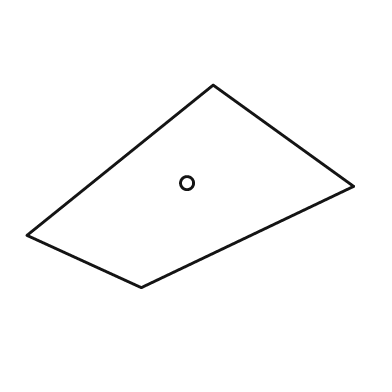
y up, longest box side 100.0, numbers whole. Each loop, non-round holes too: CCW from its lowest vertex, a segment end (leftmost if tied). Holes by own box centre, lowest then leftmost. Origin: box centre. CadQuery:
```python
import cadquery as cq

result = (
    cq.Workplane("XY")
    .moveTo(-15.0, -31.0)
    .lineTo(50.0, 0.0)
    .lineTo(7.0, 31.0)
    .lineTo(-50.0, -15.0)
    .close()
    .moveTo(-1.0, 1.0)
    .circle(2.0)
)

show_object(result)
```